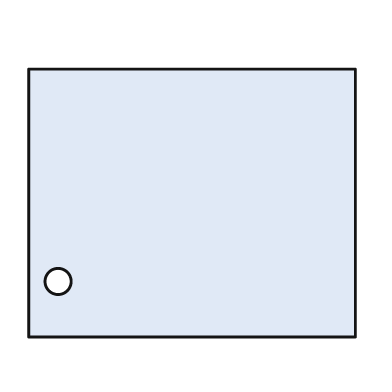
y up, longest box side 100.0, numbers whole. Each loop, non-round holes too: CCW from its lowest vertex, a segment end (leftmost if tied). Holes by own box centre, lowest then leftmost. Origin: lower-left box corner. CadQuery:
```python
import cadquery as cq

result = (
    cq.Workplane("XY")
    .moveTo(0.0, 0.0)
    .lineTo(100.0, 0.0)
    .lineTo(100.0, 82.0)
    .lineTo(0.0, 82.0)
    .close()
    .moveTo(9.0, 17.0)
    .circle(4.0)
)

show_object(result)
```